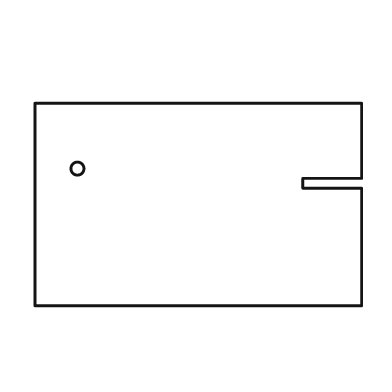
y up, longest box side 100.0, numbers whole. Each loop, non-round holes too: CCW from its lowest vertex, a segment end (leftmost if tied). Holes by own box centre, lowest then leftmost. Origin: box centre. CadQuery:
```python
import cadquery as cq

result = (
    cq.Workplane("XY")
    .moveTo(-50.0, -31.0)
    .lineTo(50.0, -31.0)
    .lineTo(50.0, 5.0)
    .lineTo(32.0, 5.0)
    .lineTo(32.0, 8.0)
    .lineTo(50.0, 8.0)
    .lineTo(50.0, 31.0)
    .lineTo(-50.0, 31.0)
    .close()
    .moveTo(-37.0, 11.0)
    .circle(2.0)
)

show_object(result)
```